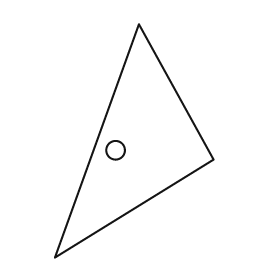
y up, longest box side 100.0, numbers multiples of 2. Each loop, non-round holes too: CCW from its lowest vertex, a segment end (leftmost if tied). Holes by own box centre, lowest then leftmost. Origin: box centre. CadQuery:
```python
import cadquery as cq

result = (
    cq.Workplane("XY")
    .moveTo(-34.0, -50.0)
    .lineTo(34.0, -8.0)
    .lineTo(2.0, 50.0)
    .close()
    .moveTo(-8.0, -4.0)
    .circle(4.0)
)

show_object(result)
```